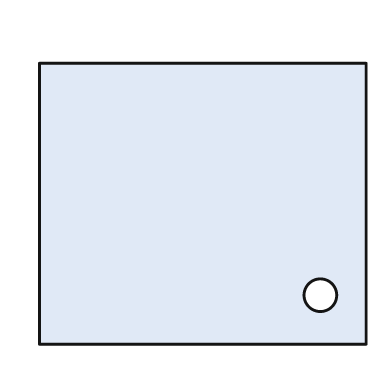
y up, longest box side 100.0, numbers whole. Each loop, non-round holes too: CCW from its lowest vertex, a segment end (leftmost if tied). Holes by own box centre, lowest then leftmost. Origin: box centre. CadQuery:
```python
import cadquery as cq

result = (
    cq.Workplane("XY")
    .moveTo(-50.0, -43.0)
    .lineTo(50.0, -43.0)
    .lineTo(50.0, 43.0)
    .lineTo(-50.0, 43.0)
    .close()
    .moveTo(36.0, -28.0)
    .circle(5.0)
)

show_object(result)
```